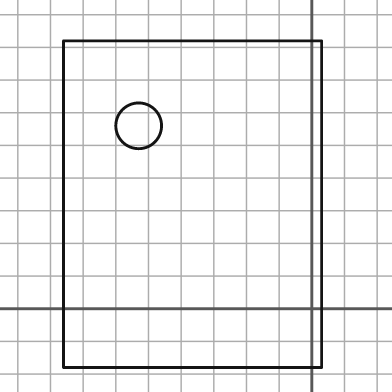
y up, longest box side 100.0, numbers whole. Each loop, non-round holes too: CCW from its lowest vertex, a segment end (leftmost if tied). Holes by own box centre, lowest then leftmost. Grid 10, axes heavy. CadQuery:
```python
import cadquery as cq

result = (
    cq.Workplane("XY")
    .moveTo(-76.0, -18.0)
    .lineTo(3.0, -18.0)
    .lineTo(3.0, 82.0)
    .lineTo(-76.0, 82.0)
    .close()
    .moveTo(-53.0, 56.0)
    .circle(7.0)
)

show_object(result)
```